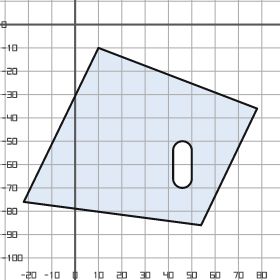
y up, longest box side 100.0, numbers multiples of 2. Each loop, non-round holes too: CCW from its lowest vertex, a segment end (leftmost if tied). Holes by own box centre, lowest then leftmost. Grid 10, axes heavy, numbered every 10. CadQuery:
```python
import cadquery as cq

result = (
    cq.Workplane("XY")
    .moveTo(54.0, -86.0)
    .lineTo(78.0, -36.0)
    .lineTo(10.0, -10.0)
    .lineTo(-22.0, -76.0)
    .close()
    .moveTo(42.0, -66.0)
    .threePointArc((46.0, -70.0), (50.0, -66.0))
    .lineTo(50.0, -54.0)
    .threePointArc((46.0, -50.0), (42.0, -54.0))
    .close()
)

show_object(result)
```